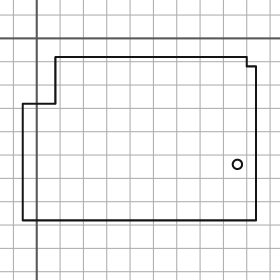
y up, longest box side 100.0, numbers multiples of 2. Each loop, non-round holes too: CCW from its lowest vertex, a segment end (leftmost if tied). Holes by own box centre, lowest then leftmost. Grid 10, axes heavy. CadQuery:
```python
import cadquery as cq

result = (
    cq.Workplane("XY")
    .moveTo(-6.0, -78.0)
    .lineTo(94.0, -78.0)
    .lineTo(94.0, -12.0)
    .lineTo(90.0, -12.0)
    .lineTo(90.0, -8.0)
    .lineTo(8.0, -8.0)
    .lineTo(8.0, -28.0)
    .lineTo(-6.0, -28.0)
    .close()
    .moveTo(86.0, -54.0)
    .circle(2.0)
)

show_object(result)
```